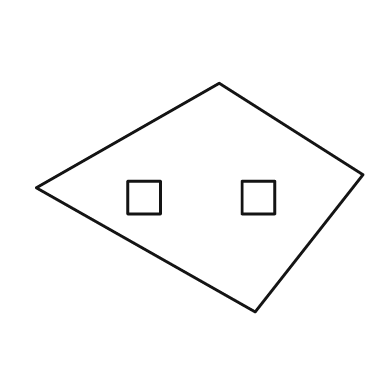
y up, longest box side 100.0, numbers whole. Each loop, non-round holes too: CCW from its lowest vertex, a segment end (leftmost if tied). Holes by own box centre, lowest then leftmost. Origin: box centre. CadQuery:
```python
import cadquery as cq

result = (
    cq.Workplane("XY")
    .moveTo(17.0, -35.0)
    .lineTo(50.0, 7.0)
    .lineTo(6.0, 35.0)
    .lineTo(-50.0, 3.0)
    .close()
    .moveTo(-22.0, -5.0)
    .lineTo(-12.0, -5.0)
    .lineTo(-12.0, 5.0)
    .lineTo(-22.0, 5.0)
    .close()
    .moveTo(13.0, -5.0)
    .lineTo(23.0, -5.0)
    .lineTo(23.0, 5.0)
    .lineTo(13.0, 5.0)
    .close()
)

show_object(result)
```